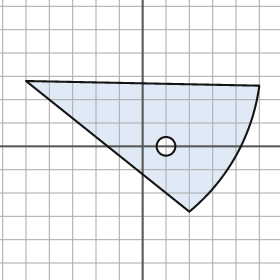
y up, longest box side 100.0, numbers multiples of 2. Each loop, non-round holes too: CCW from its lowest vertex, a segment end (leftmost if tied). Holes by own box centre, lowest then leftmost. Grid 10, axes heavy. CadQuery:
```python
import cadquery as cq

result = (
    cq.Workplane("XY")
    .moveTo(20.0, -28.0)
    .threePointArc((40.0, -4.0), (50.0, 26.0))
    .lineTo(-50.0, 28.0)
    .close()
    .moveTo(10.0, 0.0)
    .circle(4.0)
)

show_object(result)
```